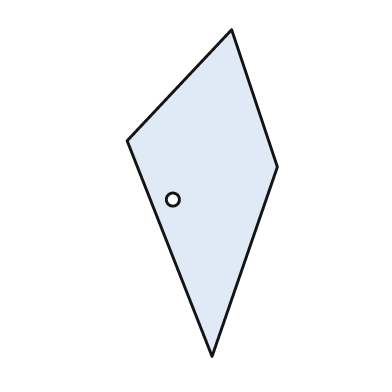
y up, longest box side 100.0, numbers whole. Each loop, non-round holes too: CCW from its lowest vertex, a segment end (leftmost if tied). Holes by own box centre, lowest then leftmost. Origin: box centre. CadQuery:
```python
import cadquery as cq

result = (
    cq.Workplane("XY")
    .moveTo(3.0, -50.0)
    .lineTo(23.0, 8.0)
    .lineTo(9.0, 50.0)
    .lineTo(-23.0, 16.0)
    .close()
    .moveTo(-9.0, -2.0)
    .circle(2.0)
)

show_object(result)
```